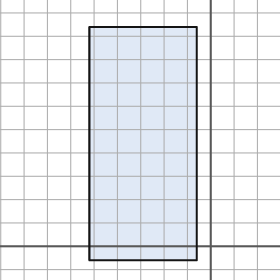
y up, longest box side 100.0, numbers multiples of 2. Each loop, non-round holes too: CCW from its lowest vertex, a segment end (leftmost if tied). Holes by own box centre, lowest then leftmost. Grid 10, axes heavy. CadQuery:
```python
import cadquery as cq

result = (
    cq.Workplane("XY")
    .moveTo(-52.0, -6.0)
    .lineTo(-6.0, -6.0)
    .lineTo(-6.0, 94.0)
    .lineTo(-52.0, 94.0)
    .close()
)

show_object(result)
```